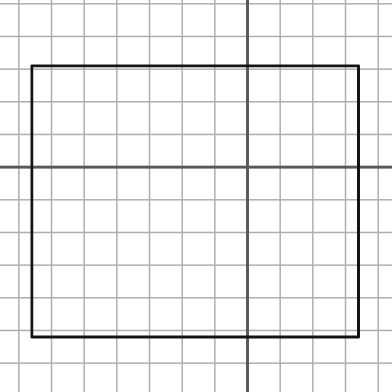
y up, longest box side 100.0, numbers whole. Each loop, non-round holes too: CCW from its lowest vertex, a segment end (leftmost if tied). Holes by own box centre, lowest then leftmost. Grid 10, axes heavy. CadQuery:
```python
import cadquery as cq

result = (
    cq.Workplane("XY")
    .moveTo(-66.0, -52.0)
    .lineTo(34.0, -52.0)
    .lineTo(34.0, 31.0)
    .lineTo(-66.0, 31.0)
    .close()
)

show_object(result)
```